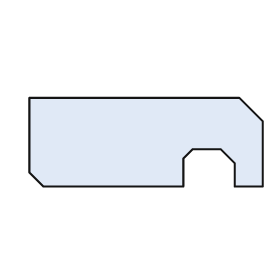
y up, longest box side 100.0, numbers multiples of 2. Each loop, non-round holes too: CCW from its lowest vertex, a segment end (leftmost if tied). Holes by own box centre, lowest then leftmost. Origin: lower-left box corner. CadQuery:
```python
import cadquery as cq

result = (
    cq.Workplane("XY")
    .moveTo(6.0, 0.0)
    .lineTo(66.0, 0.0)
    .lineTo(66.0, 12.0)
    .lineTo(70.0, 16.0)
    .lineTo(82.0, 16.0)
    .lineTo(88.0, 10.0)
    .lineTo(88.0, 0.0)
    .lineTo(100.0, 0.0)
    .lineTo(100.0, 28.0)
    .lineTo(90.0, 38.0)
    .lineTo(0.0, 38.0)
    .lineTo(0.0, 6.0)
    .close()
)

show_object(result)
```